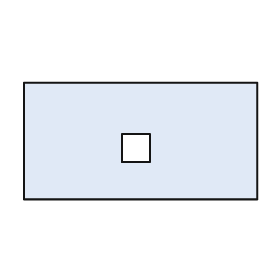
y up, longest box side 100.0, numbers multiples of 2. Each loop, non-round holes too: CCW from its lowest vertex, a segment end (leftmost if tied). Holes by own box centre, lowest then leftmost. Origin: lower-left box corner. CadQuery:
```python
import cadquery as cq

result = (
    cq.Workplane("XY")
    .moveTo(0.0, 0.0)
    .lineTo(100.0, 0.0)
    .lineTo(100.0, 50.0)
    .lineTo(0.0, 50.0)
    .close()
    .moveTo(42.0, 16.0)
    .lineTo(54.0, 16.0)
    .lineTo(54.0, 28.0)
    .lineTo(42.0, 28.0)
    .close()
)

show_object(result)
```